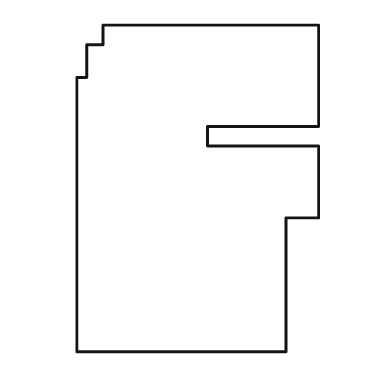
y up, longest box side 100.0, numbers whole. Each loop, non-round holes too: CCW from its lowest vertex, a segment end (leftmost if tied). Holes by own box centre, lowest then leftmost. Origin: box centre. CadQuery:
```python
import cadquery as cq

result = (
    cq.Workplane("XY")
    .moveTo(-37.0, -50.0)
    .lineTo(27.0, -50.0)
    .lineTo(27.0, -9.0)
    .lineTo(37.0, -9.0)
    .lineTo(37.0, 13.0)
    .lineTo(3.0, 13.0)
    .lineTo(3.0, 19.0)
    .lineTo(37.0, 19.0)
    .lineTo(37.0, 50.0)
    .lineTo(-29.0, 50.0)
    .lineTo(-29.0, 44.0)
    .lineTo(-34.0, 44.0)
    .lineTo(-34.0, 34.0)
    .lineTo(-37.0, 34.0)
    .close()
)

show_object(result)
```